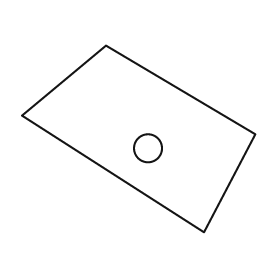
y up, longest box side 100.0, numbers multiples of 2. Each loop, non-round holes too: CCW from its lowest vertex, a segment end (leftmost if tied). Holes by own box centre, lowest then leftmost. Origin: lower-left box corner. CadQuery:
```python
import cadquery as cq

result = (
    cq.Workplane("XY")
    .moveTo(78.0, 0.0)
    .lineTo(100.0, 42.0)
    .lineTo(36.0, 80.0)
    .lineTo(0.0, 50.0)
    .close()
    .moveTo(54.0, 36.0)
    .circle(6.0)
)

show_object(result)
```